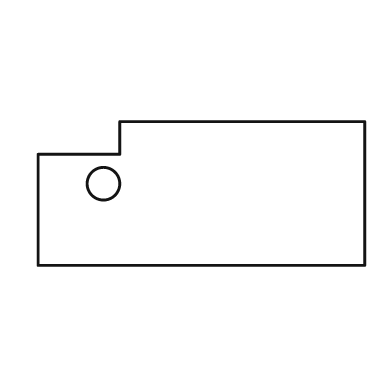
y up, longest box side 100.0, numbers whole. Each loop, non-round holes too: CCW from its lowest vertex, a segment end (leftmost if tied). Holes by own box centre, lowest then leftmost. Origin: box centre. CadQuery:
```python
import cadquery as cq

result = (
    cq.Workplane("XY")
    .moveTo(-50.0, -22.0)
    .lineTo(50.0, -22.0)
    .lineTo(50.0, 22.0)
    .lineTo(-25.0, 22.0)
    .lineTo(-25.0, 12.0)
    .lineTo(-50.0, 12.0)
    .close()
    .moveTo(-30.0, 3.0)
    .circle(5.0)
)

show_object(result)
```